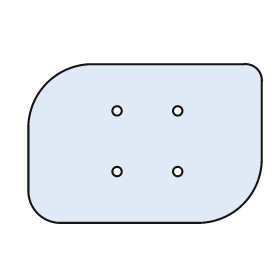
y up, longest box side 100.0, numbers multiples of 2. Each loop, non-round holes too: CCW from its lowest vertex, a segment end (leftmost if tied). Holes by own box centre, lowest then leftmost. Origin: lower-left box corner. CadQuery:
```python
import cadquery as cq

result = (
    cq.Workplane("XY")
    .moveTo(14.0, 0.0)
    .lineTo(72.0, 0.0)
    .threePointArc((92.0, 8.0), (100.0, 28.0))
    .lineTo(100.0, 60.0)
    .threePointArc((98.0, 66.0), (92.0, 68.0))
    .lineTo(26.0, 68.0)
    .threePointArc((8.0, 60.0), (0.0, 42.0))
    .lineTo(0.0, 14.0)
    .threePointArc((4.0, 4.0), (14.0, 0.0))
    .close()
    .moveTo(38.0, 22.0)
    .circle(2.0)
    .moveTo(64.0, 22.0)
    .circle(2.0)
    .moveTo(38.0, 48.0)
    .circle(2.0)
    .moveTo(64.0, 48.0)
    .circle(2.0)
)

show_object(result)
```